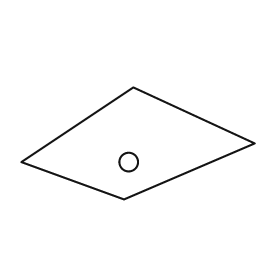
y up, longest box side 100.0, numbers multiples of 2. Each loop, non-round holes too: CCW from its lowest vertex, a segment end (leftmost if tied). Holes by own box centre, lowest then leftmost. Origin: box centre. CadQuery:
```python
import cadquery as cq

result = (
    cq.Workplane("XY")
    .moveTo(-6.0, -24.0)
    .lineTo(50.0, 0.0)
    .lineTo(-2.0, 24.0)
    .lineTo(-50.0, -8.0)
    .close()
    .moveTo(-4.0, -8.0)
    .circle(4.0)
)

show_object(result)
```